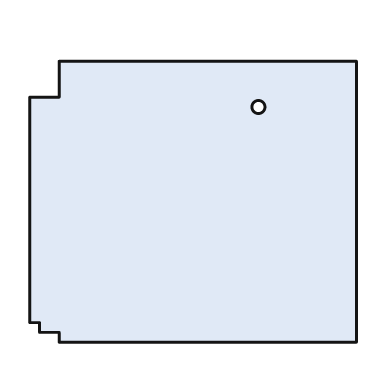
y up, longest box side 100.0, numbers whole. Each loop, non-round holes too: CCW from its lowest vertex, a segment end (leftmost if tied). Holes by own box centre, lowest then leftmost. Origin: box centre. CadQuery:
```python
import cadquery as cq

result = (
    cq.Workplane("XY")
    .moveTo(-41.0, -43.0)
    .lineTo(50.0, -43.0)
    .lineTo(50.0, 43.0)
    .lineTo(-41.0, 43.0)
    .lineTo(-41.0, 32.0)
    .lineTo(-50.0, 32.0)
    .lineTo(-50.0, -37.0)
    .lineTo(-47.0, -37.0)
    .lineTo(-47.0, -40.0)
    .lineTo(-41.0, -40.0)
    .close()
    .moveTo(20.0, 29.0)
    .circle(2.0)
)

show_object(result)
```